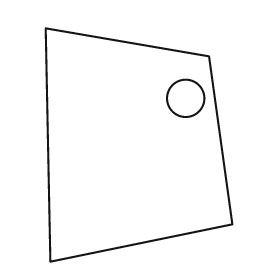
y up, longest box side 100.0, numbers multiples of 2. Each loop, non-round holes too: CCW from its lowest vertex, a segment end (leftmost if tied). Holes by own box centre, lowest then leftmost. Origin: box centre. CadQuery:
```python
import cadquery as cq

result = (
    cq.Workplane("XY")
    .moveTo(-38.0, -50.0)
    .lineTo(40.0, -34.0)
    .lineTo(30.0, 38.0)
    .lineTo(-40.0, 50.0)
    .close()
    .moveTo(20.0, 20.0)
    .circle(8.0)
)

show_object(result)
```